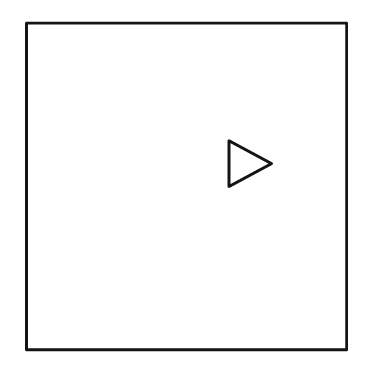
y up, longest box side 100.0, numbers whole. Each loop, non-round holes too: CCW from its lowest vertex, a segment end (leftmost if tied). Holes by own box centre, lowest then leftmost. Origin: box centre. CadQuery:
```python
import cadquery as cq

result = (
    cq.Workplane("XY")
    .moveTo(-49.0, -50.0)
    .lineTo(49.0, -50.0)
    .lineTo(49.0, 50.0)
    .lineTo(-49.0, 50.0)
    .close()
    .moveTo(13.0, 0.0)
    .lineTo(26.0, 7.0)
    .lineTo(13.0, 14.0)
    .close()
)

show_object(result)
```